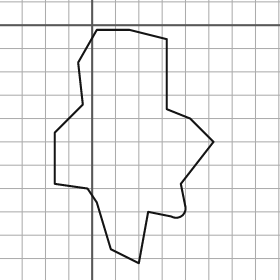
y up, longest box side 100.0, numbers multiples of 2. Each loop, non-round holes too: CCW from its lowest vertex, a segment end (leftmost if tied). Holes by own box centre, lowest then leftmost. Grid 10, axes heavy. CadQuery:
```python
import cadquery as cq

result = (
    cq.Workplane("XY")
    .moveTo(20.0, -102.0)
    .lineTo(24.0, -80.0)
    .lineTo(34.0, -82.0)
    .threePointArc((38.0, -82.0), (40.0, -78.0))
    .lineTo(38.0, -68.0)
    .lineTo(52.0, -50.0)
    .lineTo(42.0, -40.0)
    .lineTo(32.0, -36.0)
    .lineTo(32.0, -6.0)
    .lineTo(16.0, -2.0)
    .lineTo(2.0, -2.0)
    .lineTo(-6.0, -16.0)
    .lineTo(-4.0, -34.0)
    .lineTo(-16.0, -46.0)
    .lineTo(-16.0, -68.0)
    .lineTo(-2.0, -70.0)
    .lineTo(2.0, -76.0)
    .lineTo(8.0, -96.0)
    .close()
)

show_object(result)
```